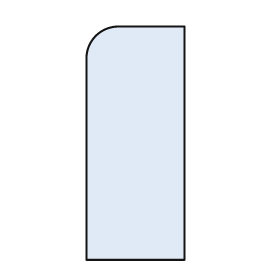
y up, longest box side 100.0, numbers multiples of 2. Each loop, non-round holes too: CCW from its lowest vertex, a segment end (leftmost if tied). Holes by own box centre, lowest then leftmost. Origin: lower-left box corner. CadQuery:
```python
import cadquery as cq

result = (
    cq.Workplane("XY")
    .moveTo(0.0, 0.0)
    .lineTo(42.0, 0.0)
    .lineTo(42.0, 100.0)
    .lineTo(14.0, 100.0)
    .threePointArc((4.0, 96.0), (0.0, 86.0))
    .close()
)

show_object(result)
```